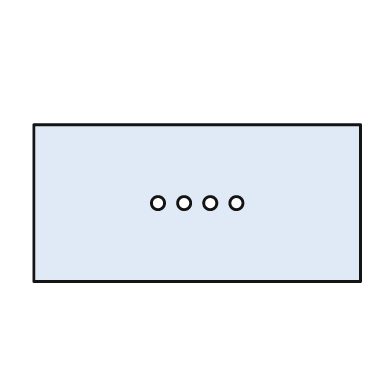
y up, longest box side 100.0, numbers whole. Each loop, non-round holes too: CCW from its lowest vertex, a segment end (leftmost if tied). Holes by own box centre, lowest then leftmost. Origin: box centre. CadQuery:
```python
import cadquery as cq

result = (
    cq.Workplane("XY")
    .moveTo(-50.0, -24.0)
    .lineTo(50.0, -24.0)
    .lineTo(50.0, 24.0)
    .lineTo(-50.0, 24.0)
    .close()
    .moveTo(-12.0, 0.0)
    .circle(2.0)
    .moveTo(-4.0, 0.0)
    .circle(2.0)
    .moveTo(4.0, 0.0)
    .circle(2.0)
    .moveTo(12.0, 0.0)
    .circle(2.0)
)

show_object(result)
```